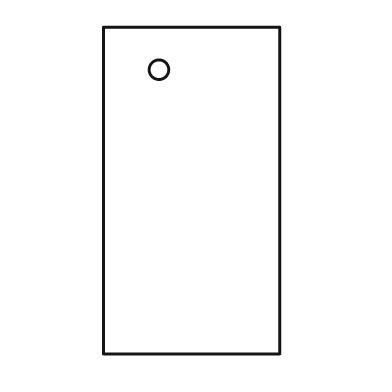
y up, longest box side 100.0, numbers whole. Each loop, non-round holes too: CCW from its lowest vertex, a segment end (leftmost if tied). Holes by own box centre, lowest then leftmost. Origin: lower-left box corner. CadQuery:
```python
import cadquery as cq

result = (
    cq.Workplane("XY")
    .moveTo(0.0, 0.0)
    .lineTo(54.0, 0.0)
    .lineTo(54.0, 100.0)
    .lineTo(0.0, 100.0)
    .close()
    .moveTo(17.0, 87.0)
    .circle(3.0)
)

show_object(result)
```